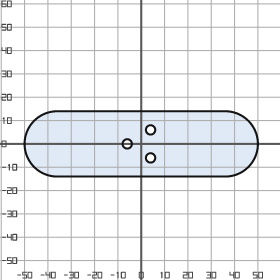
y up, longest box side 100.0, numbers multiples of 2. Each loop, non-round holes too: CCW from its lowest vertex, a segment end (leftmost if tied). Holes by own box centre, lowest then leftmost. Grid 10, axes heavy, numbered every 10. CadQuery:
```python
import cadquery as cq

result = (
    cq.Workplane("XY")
    .moveTo(-36.0, -14.0)
    .lineTo(36.0, -14.0)
    .threePointArc((50.0, 0.0), (36.0, 14.0))
    .lineTo(-36.0, 14.0)
    .threePointArc((-50.0, 0.0), (-36.0, -14.0))
    .close()
    .moveTo(4.0, -6.0)
    .circle(2.0)
    .moveTo(-6.0, 0.0)
    .circle(2.0)
    .moveTo(4.0, 6.0)
    .circle(2.0)
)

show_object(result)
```